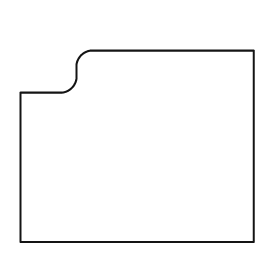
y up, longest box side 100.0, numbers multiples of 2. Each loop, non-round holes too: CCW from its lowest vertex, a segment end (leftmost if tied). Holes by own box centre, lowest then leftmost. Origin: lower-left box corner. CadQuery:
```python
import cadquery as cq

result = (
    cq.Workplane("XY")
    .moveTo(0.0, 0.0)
    .lineTo(100.0, 0.0)
    .lineTo(100.0, 82.0)
    .lineTo(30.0, 82.0)
    .threePointArc((26.0, 80.0), (24.0, 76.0))
    .lineTo(24.0, 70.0)
    .threePointArc((22.0, 66.0), (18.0, 64.0))
    .lineTo(0.0, 64.0)
    .close()
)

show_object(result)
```